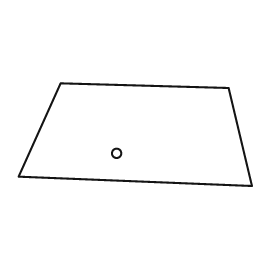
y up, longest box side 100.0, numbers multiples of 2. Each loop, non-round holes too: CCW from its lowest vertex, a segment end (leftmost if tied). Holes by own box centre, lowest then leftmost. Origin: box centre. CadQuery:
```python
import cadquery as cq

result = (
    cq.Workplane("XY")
    .moveTo(50.0, -22.0)
    .lineTo(40.0, 20.0)
    .lineTo(-32.0, 22.0)
    .lineTo(-50.0, -18.0)
    .close()
    .moveTo(-8.0, -8.0)
    .circle(2.0)
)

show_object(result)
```